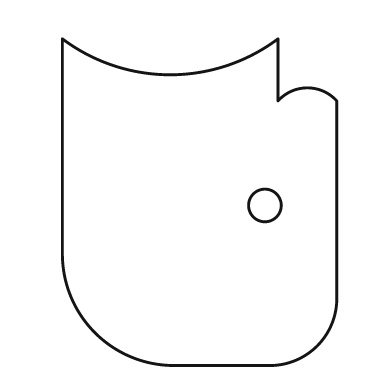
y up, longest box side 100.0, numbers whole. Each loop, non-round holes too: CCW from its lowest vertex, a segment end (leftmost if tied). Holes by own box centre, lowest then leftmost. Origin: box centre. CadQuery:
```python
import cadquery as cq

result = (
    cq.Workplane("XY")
    .moveTo(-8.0, -50.0)
    .lineTo(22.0, -50.0)
    .threePointArc((36.0, -44.0), (42.0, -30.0))
    .lineTo(42.0, 31.0)
    .threePointArc((33.0, 35.0), (24.0, 31.0))
    .lineTo(24.0, 50.0)
    .threePointArc((-9.0, 39.0), (-42.0, 50.0))
    .lineTo(-42.0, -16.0)
    .threePointArc((-32.0, -40.0), (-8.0, -50.0))
    .close()
    .moveTo(20.0, -1.0)
    .circle(5.0)
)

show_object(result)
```